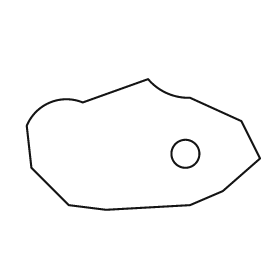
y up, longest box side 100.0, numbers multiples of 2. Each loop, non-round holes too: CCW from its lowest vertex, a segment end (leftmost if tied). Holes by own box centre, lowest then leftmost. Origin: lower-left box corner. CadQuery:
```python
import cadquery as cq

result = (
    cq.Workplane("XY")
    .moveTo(34.0, 0.0)
    .lineTo(70.0, 2.0)
    .lineTo(84.0, 8.0)
    .lineTo(100.0, 22.0)
    .lineTo(92.0, 38.0)
    .lineTo(70.0, 48.0)
    .threePointArc((60.0, 50.0), (52.0, 56.0))
    .lineTo(24.0, 46.0)
    .threePointArc((10.0, 46.0), (0.0, 36.0))
    .lineTo(2.0, 18.0)
    .lineTo(18.0, 2.0)
    .close()
    .moveTo(68.0, 24.0)
    .circle(6.0)
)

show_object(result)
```